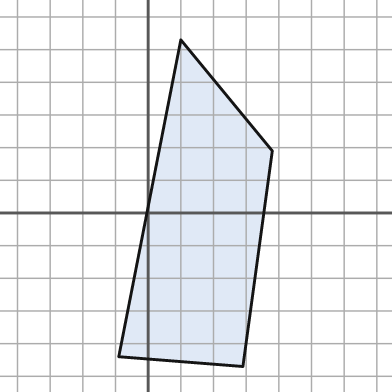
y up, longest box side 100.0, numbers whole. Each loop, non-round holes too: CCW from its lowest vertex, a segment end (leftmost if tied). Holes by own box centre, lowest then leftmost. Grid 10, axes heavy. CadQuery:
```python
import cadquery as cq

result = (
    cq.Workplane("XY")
    .moveTo(29.0, -47.0)
    .lineTo(38.0, 19.0)
    .lineTo(10.0, 53.0)
    .lineTo(-9.0, -44.0)
    .close()
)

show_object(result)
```